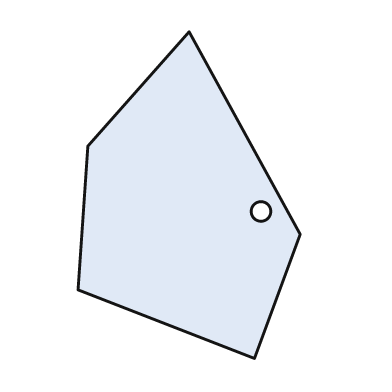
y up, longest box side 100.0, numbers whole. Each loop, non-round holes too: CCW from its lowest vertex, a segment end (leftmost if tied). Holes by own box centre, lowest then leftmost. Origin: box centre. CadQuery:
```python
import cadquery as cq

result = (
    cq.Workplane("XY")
    .moveTo(20.0, -50.0)
    .lineTo(34.0, -12.0)
    .lineTo(0.0, 50.0)
    .lineTo(-31.0, 15.0)
    .lineTo(-34.0, -29.0)
    .close()
    .moveTo(22.0, -5.0)
    .circle(3.0)
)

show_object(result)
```